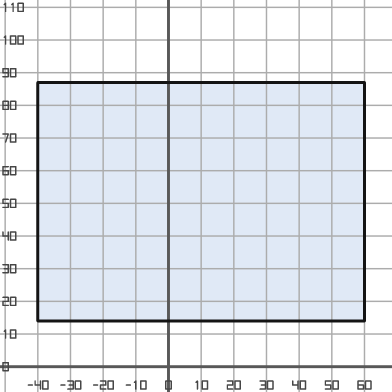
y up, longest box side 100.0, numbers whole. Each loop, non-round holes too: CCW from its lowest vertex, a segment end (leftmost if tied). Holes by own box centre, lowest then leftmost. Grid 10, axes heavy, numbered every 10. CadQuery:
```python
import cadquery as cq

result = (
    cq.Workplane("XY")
    .moveTo(-40.0, 14.0)
    .lineTo(60.0, 14.0)
    .lineTo(60.0, 87.0)
    .lineTo(-40.0, 87.0)
    .close()
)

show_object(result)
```